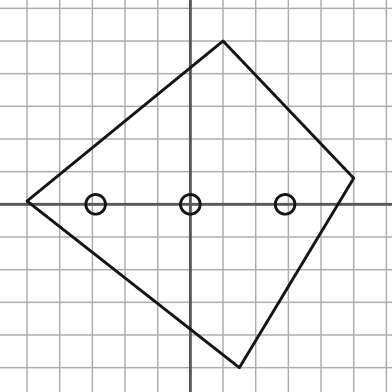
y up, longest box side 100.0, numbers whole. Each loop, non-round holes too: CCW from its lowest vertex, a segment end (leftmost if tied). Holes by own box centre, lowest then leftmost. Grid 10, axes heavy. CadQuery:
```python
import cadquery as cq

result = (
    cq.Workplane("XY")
    .moveTo(15.0, -50.0)
    .lineTo(50.0, 8.0)
    .lineTo(10.0, 50.0)
    .lineTo(-50.0, 1.0)
    .close()
    .moveTo(-29.0, 0.0)
    .circle(3.0)
    .moveTo(0.0, 0.0)
    .circle(3.0)
    .moveTo(29.0, 0.0)
    .circle(3.0)
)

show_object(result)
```